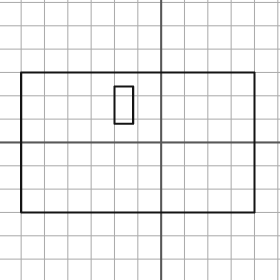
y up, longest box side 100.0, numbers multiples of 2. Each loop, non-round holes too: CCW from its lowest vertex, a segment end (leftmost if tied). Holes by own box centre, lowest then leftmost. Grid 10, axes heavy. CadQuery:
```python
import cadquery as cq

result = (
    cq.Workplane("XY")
    .moveTo(-60.0, -30.0)
    .lineTo(40.0, -30.0)
    .lineTo(40.0, 30.0)
    .lineTo(-60.0, 30.0)
    .close()
    .moveTo(-20.0, 8.0)
    .lineTo(-12.0, 8.0)
    .lineTo(-12.0, 24.0)
    .lineTo(-20.0, 24.0)
    .close()
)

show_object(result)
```